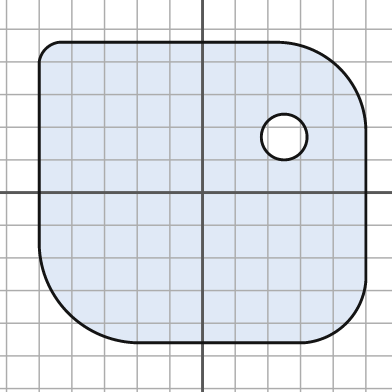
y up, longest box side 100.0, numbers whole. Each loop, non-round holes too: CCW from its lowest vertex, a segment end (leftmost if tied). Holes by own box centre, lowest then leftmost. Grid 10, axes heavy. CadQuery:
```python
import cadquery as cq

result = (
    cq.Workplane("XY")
    .moveTo(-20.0, -46.0)
    .lineTo(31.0, -46.0)
    .threePointArc((44.0, -40.0), (50.0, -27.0))
    .lineTo(50.0, 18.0)
    .threePointArc((42.0, 38.0), (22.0, 46.0))
    .lineTo(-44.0, 46.0)
    .threePointArc((-48.0, 44.0), (-50.0, 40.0))
    .lineTo(-50.0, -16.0)
    .threePointArc((-41.0, -37.0), (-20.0, -46.0))
    .close()
    .moveTo(25.0, 17.0)
    .circle(7.0)
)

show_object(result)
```